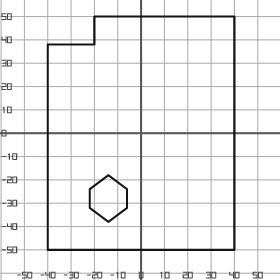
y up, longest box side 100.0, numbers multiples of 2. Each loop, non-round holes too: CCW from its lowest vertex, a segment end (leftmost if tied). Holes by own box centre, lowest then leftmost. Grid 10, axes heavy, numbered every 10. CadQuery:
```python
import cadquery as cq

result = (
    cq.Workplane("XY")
    .moveTo(-40.0, -50.0)
    .lineTo(40.0, -50.0)
    .lineTo(40.0, 50.0)
    .lineTo(-20.0, 50.0)
    .lineTo(-20.0, 38.0)
    .lineTo(-40.0, 38.0)
    .close()
    .moveTo(-14.0, -38.0)
    .lineTo(-6.0, -32.0)
    .lineTo(-6.0, -24.0)
    .lineTo(-14.0, -18.0)
    .lineTo(-22.0, -24.0)
    .lineTo(-22.0, -32.0)
    .close()
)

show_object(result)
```